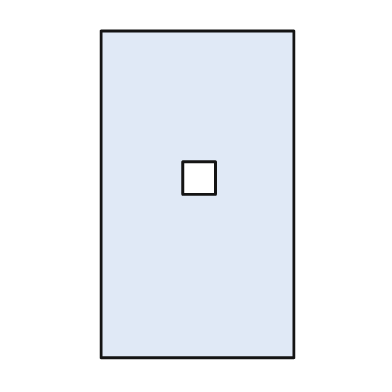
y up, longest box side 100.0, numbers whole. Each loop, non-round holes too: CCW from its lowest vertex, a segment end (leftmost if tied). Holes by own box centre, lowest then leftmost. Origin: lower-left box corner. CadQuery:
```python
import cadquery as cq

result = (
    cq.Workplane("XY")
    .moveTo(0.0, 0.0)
    .lineTo(59.0, 0.0)
    .lineTo(59.0, 100.0)
    .lineTo(0.0, 100.0)
    .close()
    .moveTo(25.0, 50.0)
    .lineTo(35.0, 50.0)
    .lineTo(35.0, 60.0)
    .lineTo(25.0, 60.0)
    .close()
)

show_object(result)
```